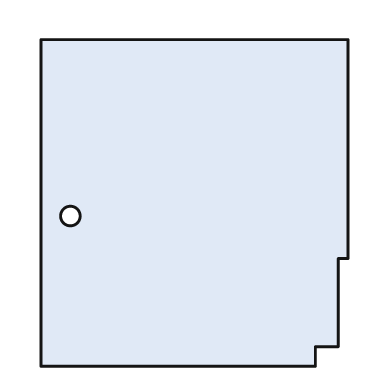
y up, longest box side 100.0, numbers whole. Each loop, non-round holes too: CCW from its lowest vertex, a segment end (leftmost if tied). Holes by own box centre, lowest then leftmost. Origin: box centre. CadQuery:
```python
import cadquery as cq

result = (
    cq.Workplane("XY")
    .moveTo(-47.0, -50.0)
    .lineTo(37.0, -50.0)
    .lineTo(37.0, -44.0)
    .lineTo(44.0, -44.0)
    .lineTo(44.0, -17.0)
    .lineTo(47.0, -17.0)
    .lineTo(47.0, 50.0)
    .lineTo(-47.0, 50.0)
    .close()
    .moveTo(-38.0, -4.0)
    .circle(3.0)
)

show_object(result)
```